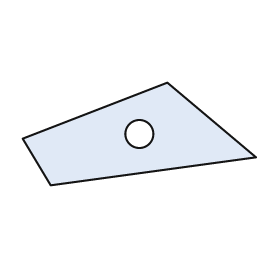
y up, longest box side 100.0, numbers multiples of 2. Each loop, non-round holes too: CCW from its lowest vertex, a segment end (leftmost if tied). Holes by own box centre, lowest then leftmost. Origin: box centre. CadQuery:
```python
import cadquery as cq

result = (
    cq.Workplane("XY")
    .moveTo(-38.0, -22.0)
    .lineTo(50.0, -10.0)
    .lineTo(12.0, 22.0)
    .lineTo(-50.0, -2.0)
    .close()
    .moveTo(0.0, 0.0)
    .circle(6.0)
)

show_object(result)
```